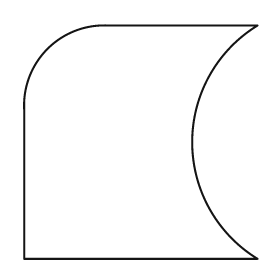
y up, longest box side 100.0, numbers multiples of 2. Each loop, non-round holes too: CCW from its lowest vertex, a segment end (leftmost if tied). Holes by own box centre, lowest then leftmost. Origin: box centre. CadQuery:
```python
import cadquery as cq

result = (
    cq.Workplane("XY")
    .moveTo(-50.0, -50.0)
    .lineTo(50.0, -50.0)
    .threePointArc((22.0, 0.0), (50.0, 50.0))
    .lineTo(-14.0, 50.0)
    .threePointArc((-40.0, 40.0), (-50.0, 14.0))
    .close()
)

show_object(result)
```